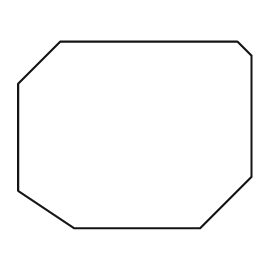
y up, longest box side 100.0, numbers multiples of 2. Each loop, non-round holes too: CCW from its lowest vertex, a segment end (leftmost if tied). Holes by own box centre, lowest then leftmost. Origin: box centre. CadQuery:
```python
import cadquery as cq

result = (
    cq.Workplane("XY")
    .moveTo(-26.0, -40.0)
    .lineTo(28.0, -40.0)
    .lineTo(50.0, -18.0)
    .lineTo(50.0, 34.0)
    .lineTo(44.0, 40.0)
    .lineTo(-32.0, 40.0)
    .lineTo(-50.0, 22.0)
    .lineTo(-50.0, -24.0)
    .close()
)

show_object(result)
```